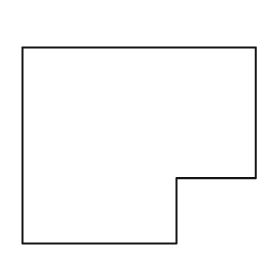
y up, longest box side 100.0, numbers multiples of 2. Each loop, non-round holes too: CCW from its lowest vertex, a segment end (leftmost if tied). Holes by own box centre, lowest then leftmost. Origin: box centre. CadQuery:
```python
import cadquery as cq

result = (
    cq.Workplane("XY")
    .moveTo(-50.0, -42.0)
    .lineTo(16.0, -42.0)
    .lineTo(16.0, -14.0)
    .lineTo(50.0, -14.0)
    .lineTo(50.0, 42.0)
    .lineTo(-50.0, 42.0)
    .close()
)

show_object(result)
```